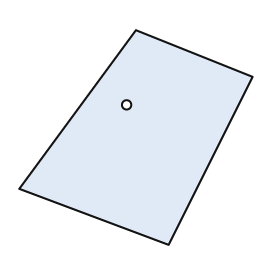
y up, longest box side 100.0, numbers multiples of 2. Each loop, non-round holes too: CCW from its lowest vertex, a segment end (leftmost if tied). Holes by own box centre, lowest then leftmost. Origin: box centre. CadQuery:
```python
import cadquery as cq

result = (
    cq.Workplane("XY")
    .moveTo(14.0, -46.0)
    .lineTo(50.0, 26.0)
    .lineTo(0.0, 46.0)
    .lineTo(-50.0, -22.0)
    .close()
    .moveTo(-4.0, 14.0)
    .circle(2.0)
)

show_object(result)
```